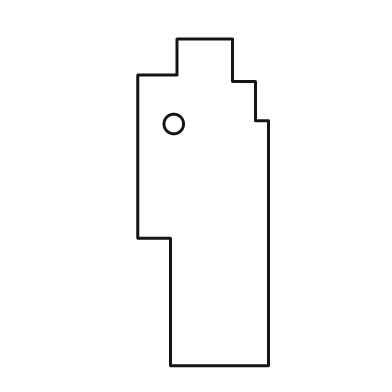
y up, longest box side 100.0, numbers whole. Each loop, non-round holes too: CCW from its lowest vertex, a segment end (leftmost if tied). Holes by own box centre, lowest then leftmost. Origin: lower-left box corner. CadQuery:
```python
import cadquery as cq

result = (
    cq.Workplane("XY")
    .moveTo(10.0, 0.0)
    .lineTo(40.0, 0.0)
    .lineTo(40.0, 75.0)
    .lineTo(36.0, 75.0)
    .lineTo(36.0, 87.0)
    .lineTo(29.0, 87.0)
    .lineTo(29.0, 100.0)
    .lineTo(12.0, 100.0)
    .lineTo(12.0, 89.0)
    .lineTo(0.0, 89.0)
    .lineTo(0.0, 39.0)
    .lineTo(10.0, 39.0)
    .close()
    .moveTo(11.0, 74.0)
    .circle(3.0)
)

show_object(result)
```